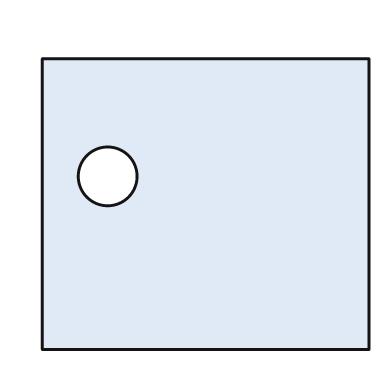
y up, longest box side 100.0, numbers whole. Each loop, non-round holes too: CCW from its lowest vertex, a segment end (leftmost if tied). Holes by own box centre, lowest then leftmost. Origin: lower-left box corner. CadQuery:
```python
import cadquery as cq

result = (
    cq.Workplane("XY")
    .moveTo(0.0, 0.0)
    .lineTo(100.0, 0.0)
    .lineTo(100.0, 89.0)
    .lineTo(0.0, 89.0)
    .close()
    .moveTo(20.0, 53.0)
    .circle(9.0)
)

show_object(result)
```